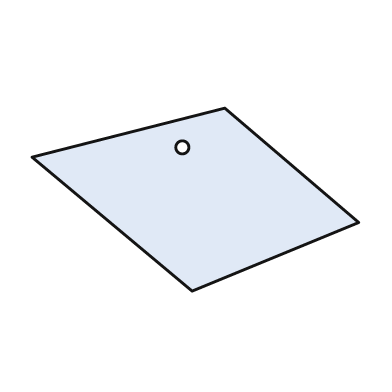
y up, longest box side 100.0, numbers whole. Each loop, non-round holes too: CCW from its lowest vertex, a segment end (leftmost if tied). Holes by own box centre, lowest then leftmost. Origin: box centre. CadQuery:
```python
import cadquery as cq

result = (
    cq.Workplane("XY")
    .moveTo(-1.0, -28.0)
    .lineTo(50.0, -7.0)
    .lineTo(9.0, 28.0)
    .lineTo(-50.0, 13.0)
    .close()
    .moveTo(-4.0, 16.0)
    .circle(2.0)
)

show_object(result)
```